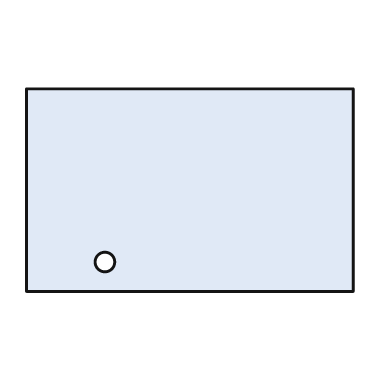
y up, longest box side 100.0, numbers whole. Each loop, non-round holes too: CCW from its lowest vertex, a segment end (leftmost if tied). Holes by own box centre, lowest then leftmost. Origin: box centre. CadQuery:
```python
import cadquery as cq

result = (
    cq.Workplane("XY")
    .moveTo(-50.0, -31.0)
    .lineTo(50.0, -31.0)
    .lineTo(50.0, 31.0)
    .lineTo(-50.0, 31.0)
    .close()
    .moveTo(-26.0, -22.0)
    .circle(3.0)
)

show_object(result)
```